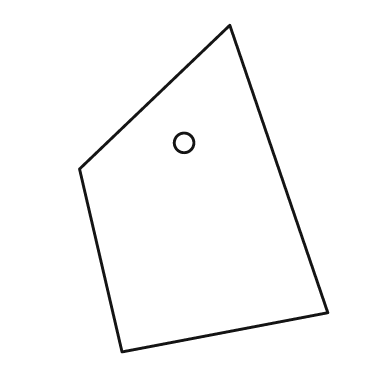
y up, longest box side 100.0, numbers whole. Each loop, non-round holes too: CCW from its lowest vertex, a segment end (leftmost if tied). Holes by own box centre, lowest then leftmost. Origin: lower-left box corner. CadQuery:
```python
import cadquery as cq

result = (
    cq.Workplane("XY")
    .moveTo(13.0, 0.0)
    .lineTo(76.0, 12.0)
    .lineTo(46.0, 100.0)
    .lineTo(0.0, 56.0)
    .close()
    .moveTo(32.0, 64.0)
    .circle(3.0)
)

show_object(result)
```